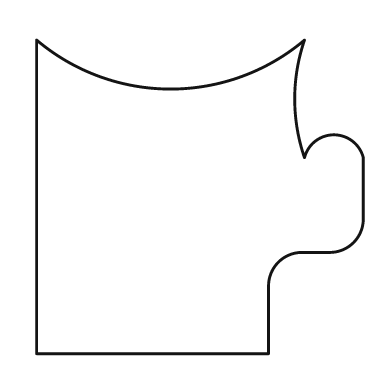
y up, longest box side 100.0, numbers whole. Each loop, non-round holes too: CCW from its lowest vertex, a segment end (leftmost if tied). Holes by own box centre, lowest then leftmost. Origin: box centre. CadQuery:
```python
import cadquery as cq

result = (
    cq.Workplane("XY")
    .moveTo(-50.0, -48.0)
    .lineTo(21.0, -48.0)
    .lineTo(21.0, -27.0)
    .threePointArc((24.0, -20.0), (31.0, -17.0))
    .lineTo(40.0, -17.0)
    .threePointArc((47.0, -14.0), (50.0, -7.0))
    .lineTo(50.0, 12.0)
    .threePointArc((41.0, 19.0), (32.0, 12.0))
    .threePointArc((29.0, 30.0), (32.0, 48.0))
    .threePointArc((-9.0, 33.0), (-50.0, 48.0))
    .close()
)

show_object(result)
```